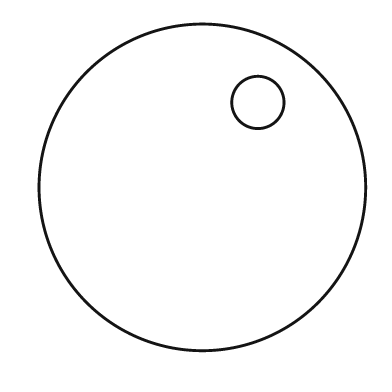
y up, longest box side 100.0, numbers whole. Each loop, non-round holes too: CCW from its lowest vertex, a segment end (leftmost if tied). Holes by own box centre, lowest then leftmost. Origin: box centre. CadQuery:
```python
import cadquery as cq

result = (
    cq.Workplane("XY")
    .moveTo(0.0, 0.0)
    .circle(50.0)
    .moveTo(17.0, 26.0)
    .circle(8.0)
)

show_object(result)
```